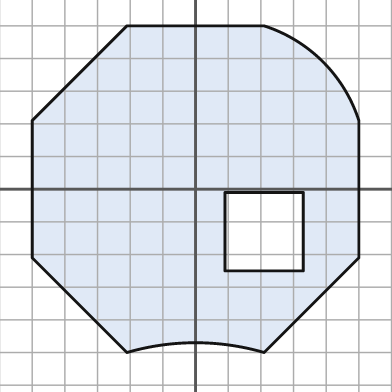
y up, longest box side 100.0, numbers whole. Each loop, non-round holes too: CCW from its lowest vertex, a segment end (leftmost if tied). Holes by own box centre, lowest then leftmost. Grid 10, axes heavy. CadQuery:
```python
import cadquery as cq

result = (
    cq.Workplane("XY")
    .moveTo(-21.0, -50.0)
    .threePointArc((0.0, -47.0), (21.0, -50.0))
    .lineTo(50.0, -21.0)
    .lineTo(50.0, 21.0)
    .threePointArc((39.0, 39.0), (21.0, 50.0))
    .lineTo(-21.0, 50.0)
    .lineTo(-50.0, 21.0)
    .lineTo(-50.0, -21.0)
    .close()
    .moveTo(9.0, -25.0)
    .lineTo(33.0, -25.0)
    .lineTo(33.0, -1.0)
    .lineTo(9.0, -1.0)
    .close()
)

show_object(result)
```